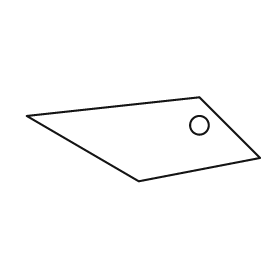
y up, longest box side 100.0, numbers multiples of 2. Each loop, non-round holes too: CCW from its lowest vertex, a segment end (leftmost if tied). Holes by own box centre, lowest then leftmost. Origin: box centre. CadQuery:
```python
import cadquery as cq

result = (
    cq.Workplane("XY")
    .moveTo(-2.0, -18.0)
    .lineTo(50.0, -8.0)
    .lineTo(24.0, 18.0)
    .lineTo(-50.0, 10.0)
    .close()
    .moveTo(24.0, 6.0)
    .circle(4.0)
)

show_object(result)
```